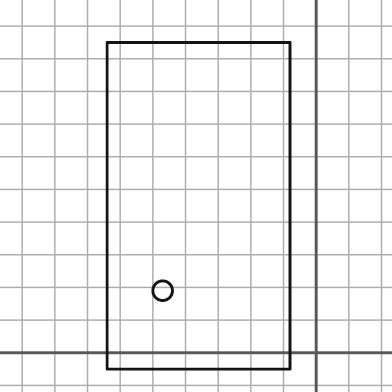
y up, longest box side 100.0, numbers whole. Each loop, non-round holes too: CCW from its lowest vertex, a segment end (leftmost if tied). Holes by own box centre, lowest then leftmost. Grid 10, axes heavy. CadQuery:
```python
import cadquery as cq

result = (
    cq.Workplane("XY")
    .moveTo(-64.0, -5.0)
    .lineTo(-8.0, -5.0)
    .lineTo(-8.0, 95.0)
    .lineTo(-64.0, 95.0)
    .close()
    .moveTo(-47.0, 19.0)
    .circle(3.0)
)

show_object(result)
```